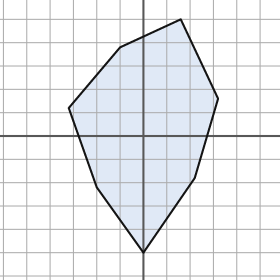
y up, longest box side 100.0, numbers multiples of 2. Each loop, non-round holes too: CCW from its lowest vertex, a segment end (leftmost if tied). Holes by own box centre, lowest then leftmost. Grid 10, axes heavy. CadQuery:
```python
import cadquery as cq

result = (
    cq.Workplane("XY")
    .moveTo(0.0, -50.0)
    .lineTo(22.0, -18.0)
    .lineTo(32.0, 16.0)
    .lineTo(16.0, 50.0)
    .lineTo(-10.0, 38.0)
    .lineTo(-32.0, 12.0)
    .lineTo(-20.0, -22.0)
    .close()
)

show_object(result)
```